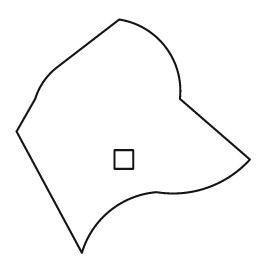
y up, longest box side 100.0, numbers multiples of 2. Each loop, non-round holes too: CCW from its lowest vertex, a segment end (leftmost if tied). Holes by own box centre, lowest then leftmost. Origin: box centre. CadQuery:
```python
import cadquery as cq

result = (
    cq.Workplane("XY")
    .moveTo(-22.0, -50.0)
    .threePointArc((-10.0, -32.0), (10.0, -24.0))
    .threePointArc((32.0, -22.0), (50.0, -10.0))
    .lineTo(20.0, 16.0)
    .threePointArc((14.0, 38.0), (-6.0, 50.0))
    .lineTo(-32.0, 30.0)
    .threePointArc((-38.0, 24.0), (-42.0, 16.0))
    .lineTo(-50.0, 2.0)
    .close()
    .moveTo(-8.0, -14.0)
    .lineTo(0.0, -14.0)
    .lineTo(0.0, -6.0)
    .lineTo(-8.0, -6.0)
    .close()
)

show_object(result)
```